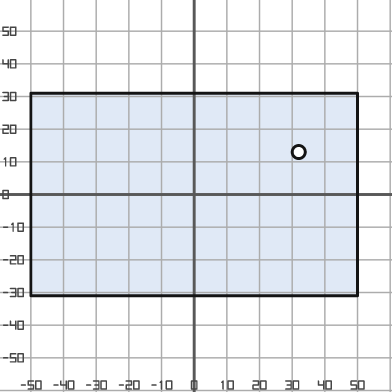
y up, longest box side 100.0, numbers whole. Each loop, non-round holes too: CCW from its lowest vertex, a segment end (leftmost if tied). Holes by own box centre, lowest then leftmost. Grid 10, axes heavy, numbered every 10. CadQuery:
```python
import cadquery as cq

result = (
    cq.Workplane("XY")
    .moveTo(-50.0, -31.0)
    .lineTo(50.0, -31.0)
    .lineTo(50.0, 31.0)
    .lineTo(-50.0, 31.0)
    .close()
    .moveTo(32.0, 13.0)
    .circle(2.0)
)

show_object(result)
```